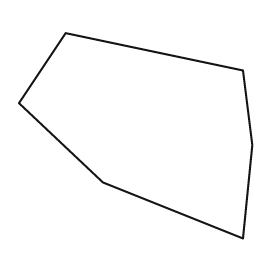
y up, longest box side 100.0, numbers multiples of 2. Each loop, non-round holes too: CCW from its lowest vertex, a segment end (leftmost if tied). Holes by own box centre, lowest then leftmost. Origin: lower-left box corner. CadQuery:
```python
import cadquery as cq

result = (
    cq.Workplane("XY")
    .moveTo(96.0, 0.0)
    .lineTo(100.0, 40.0)
    .lineTo(96.0, 72.0)
    .lineTo(20.0, 88.0)
    .lineTo(0.0, 58.0)
    .lineTo(36.0, 24.0)
    .close()
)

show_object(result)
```